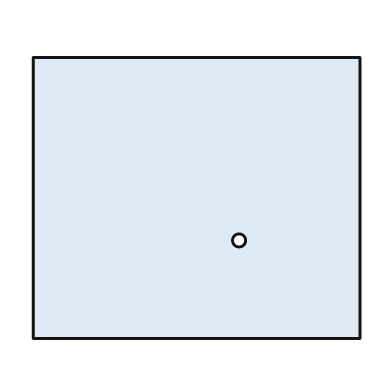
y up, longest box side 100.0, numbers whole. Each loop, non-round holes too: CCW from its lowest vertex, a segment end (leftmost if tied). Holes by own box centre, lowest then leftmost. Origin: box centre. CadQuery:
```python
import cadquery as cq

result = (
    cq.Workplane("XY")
    .moveTo(-50.0, -43.0)
    .lineTo(50.0, -43.0)
    .lineTo(50.0, 43.0)
    .lineTo(-50.0, 43.0)
    .close()
    .moveTo(13.0, -13.0)
    .circle(2.0)
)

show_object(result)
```